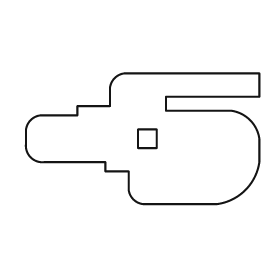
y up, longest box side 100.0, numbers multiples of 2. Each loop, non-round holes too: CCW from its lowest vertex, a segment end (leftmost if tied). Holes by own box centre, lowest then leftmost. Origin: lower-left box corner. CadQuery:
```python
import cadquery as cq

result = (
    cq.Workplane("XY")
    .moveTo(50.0, 0.0)
    .lineTo(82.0, 0.0)
    .threePointArc((94.0, 6.0), (100.0, 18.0))
    .lineTo(100.0, 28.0)
    .threePointArc((96.0, 36.0), (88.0, 40.0))
    .lineTo(60.0, 40.0)
    .lineTo(60.0, 46.0)
    .lineTo(100.0, 46.0)
    .lineTo(100.0, 56.0)
    .lineTo(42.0, 56.0)
    .threePointArc((38.0, 54.0), (36.0, 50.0))
    .lineTo(36.0, 42.0)
    .lineTo(22.0, 42.0)
    .lineTo(22.0, 38.0)
    .lineTo(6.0, 38.0)
    .threePointArc((2.0, 36.0), (0.0, 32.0))
    .lineTo(0.0, 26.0)
    .threePointArc((2.0, 20.0), (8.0, 18.0))
    .lineTo(34.0, 18.0)
    .lineTo(34.0, 14.0)
    .lineTo(44.0, 14.0)
    .lineTo(44.0, 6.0)
    .threePointArc((46.0, 2.0), (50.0, 0.0))
    .close()
    .moveTo(48.0, 24.0)
    .lineTo(56.0, 24.0)
    .lineTo(56.0, 32.0)
    .lineTo(48.0, 32.0)
    .close()
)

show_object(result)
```